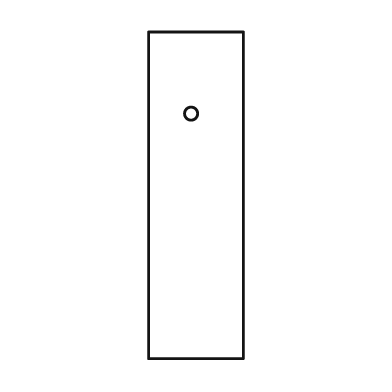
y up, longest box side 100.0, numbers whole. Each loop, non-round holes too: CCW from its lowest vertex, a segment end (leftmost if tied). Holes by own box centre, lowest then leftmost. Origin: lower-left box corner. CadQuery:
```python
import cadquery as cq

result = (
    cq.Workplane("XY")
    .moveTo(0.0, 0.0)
    .lineTo(29.0, 0.0)
    .lineTo(29.0, 100.0)
    .lineTo(0.0, 100.0)
    .close()
    .moveTo(13.0, 75.0)
    .circle(2.0)
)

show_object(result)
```